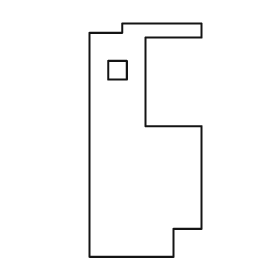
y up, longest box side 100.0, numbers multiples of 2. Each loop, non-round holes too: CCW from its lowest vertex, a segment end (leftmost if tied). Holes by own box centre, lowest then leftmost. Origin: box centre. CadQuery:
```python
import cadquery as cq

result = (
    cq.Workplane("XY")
    .moveTo(-24.0, -50.0)
    .lineTo(12.0, -50.0)
    .lineTo(12.0, -38.0)
    .lineTo(24.0, -38.0)
    .lineTo(24.0, 6.0)
    .lineTo(0.0, 6.0)
    .lineTo(0.0, 44.0)
    .lineTo(24.0, 44.0)
    .lineTo(24.0, 50.0)
    .lineTo(-10.0, 50.0)
    .lineTo(-10.0, 46.0)
    .lineTo(-24.0, 46.0)
    .close()
    .moveTo(-16.0, 26.0)
    .lineTo(-8.0, 26.0)
    .lineTo(-8.0, 34.0)
    .lineTo(-16.0, 34.0)
    .close()
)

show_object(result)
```